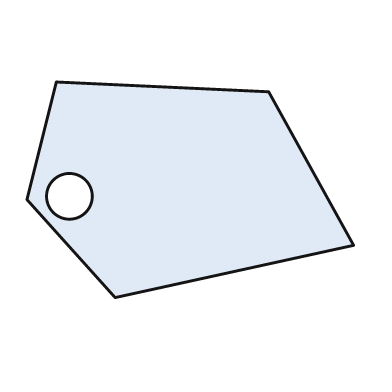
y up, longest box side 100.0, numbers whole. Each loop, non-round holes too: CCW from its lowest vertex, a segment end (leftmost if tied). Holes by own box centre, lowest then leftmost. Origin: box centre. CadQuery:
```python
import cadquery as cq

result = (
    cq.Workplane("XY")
    .moveTo(-23.0, -33.0)
    .lineTo(50.0, -17.0)
    .lineTo(24.0, 30.0)
    .lineTo(-41.0, 33.0)
    .lineTo(-50.0, -3.0)
    .close()
    .moveTo(-37.0, -2.0)
    .circle(7.0)
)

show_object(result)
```